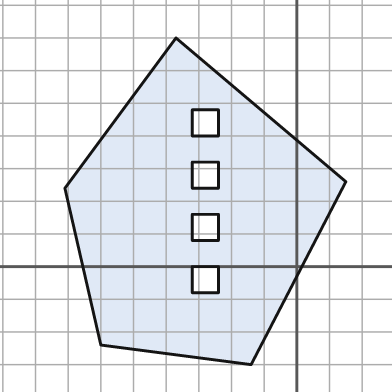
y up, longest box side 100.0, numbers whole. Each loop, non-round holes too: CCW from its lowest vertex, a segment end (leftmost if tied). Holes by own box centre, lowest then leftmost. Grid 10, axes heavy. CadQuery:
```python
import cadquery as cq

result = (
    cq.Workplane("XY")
    .moveTo(-14.0, -30.0)
    .lineTo(15.0, 26.0)
    .lineTo(-37.0, 70.0)
    .lineTo(-71.0, 24.0)
    .lineTo(-60.0, -24.0)
    .close()
    .moveTo(-32.0, -8.0)
    .lineTo(-24.0, -8.0)
    .lineTo(-24.0, 0.0)
    .lineTo(-32.0, 0.0)
    .close()
    .moveTo(-32.0, 8.0)
    .lineTo(-24.0, 8.0)
    .lineTo(-24.0, 16.0)
    .lineTo(-32.0, 16.0)
    .close()
    .moveTo(-32.0, 24.0)
    .lineTo(-24.0, 24.0)
    .lineTo(-24.0, 32.0)
    .lineTo(-32.0, 32.0)
    .close()
    .moveTo(-32.0, 40.0)
    .lineTo(-24.0, 40.0)
    .lineTo(-24.0, 48.0)
    .lineTo(-32.0, 48.0)
    .close()
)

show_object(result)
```